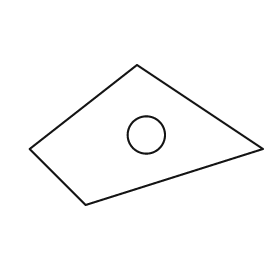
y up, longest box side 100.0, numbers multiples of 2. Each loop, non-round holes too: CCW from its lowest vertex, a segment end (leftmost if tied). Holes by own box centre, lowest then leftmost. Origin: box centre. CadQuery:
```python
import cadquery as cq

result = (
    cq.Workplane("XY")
    .moveTo(-26.0, -30.0)
    .lineTo(50.0, -6.0)
    .lineTo(-4.0, 30.0)
    .lineTo(-50.0, -6.0)
    .close()
    .moveTo(0.0, 0.0)
    .circle(8.0)
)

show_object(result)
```